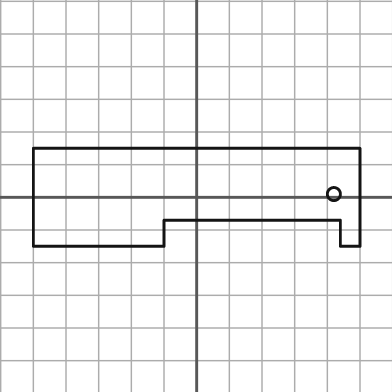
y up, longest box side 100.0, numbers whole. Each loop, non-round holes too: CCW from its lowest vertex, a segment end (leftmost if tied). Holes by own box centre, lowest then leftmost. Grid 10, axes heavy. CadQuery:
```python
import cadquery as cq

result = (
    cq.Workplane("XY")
    .moveTo(-50.0, -15.0)
    .lineTo(-10.0, -15.0)
    .lineTo(-10.0, -7.0)
    .lineTo(44.0, -7.0)
    .lineTo(44.0, -15.0)
    .lineTo(50.0, -15.0)
    .lineTo(50.0, 15.0)
    .lineTo(-50.0, 15.0)
    .close()
    .moveTo(42.0, 1.0)
    .circle(2.0)
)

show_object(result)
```